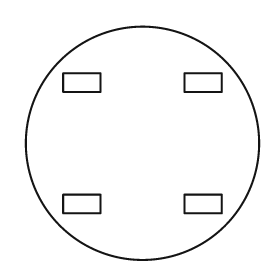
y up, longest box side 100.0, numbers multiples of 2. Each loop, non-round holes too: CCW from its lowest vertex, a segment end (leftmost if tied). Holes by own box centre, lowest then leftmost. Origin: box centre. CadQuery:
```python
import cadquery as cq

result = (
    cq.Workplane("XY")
    .moveTo(0.0, 0.0)
    .circle(50.0)
    .moveTo(-34.0, -30.0)
    .lineTo(-18.0, -30.0)
    .lineTo(-18.0, -22.0)
    .lineTo(-34.0, -22.0)
    .close()
    .moveTo(18.0, -30.0)
    .lineTo(34.0, -30.0)
    .lineTo(34.0, -22.0)
    .lineTo(18.0, -22.0)
    .close()
    .moveTo(-34.0, 22.0)
    .lineTo(-18.0, 22.0)
    .lineTo(-18.0, 30.0)
    .lineTo(-34.0, 30.0)
    .close()
    .moveTo(18.0, 22.0)
    .lineTo(34.0, 22.0)
    .lineTo(34.0, 30.0)
    .lineTo(18.0, 30.0)
    .close()
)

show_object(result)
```